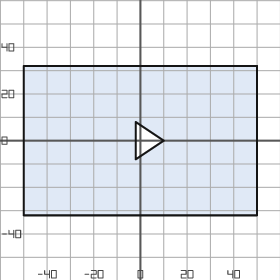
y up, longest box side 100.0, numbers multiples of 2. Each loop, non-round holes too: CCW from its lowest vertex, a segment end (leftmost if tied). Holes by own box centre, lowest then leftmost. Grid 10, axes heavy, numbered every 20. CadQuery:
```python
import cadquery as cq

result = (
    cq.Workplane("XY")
    .moveTo(-50.0, -32.0)
    .lineTo(50.0, -32.0)
    .lineTo(50.0, 32.0)
    .lineTo(-50.0, 32.0)
    .close()
    .moveTo(-2.0, -8.0)
    .lineTo(10.0, 0.0)
    .lineTo(-2.0, 8.0)
    .close()
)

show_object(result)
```